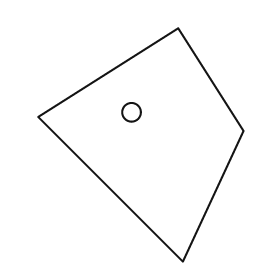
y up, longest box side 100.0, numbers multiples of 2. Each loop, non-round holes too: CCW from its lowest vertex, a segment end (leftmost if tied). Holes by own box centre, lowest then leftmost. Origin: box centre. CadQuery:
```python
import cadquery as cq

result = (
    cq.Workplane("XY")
    .moveTo(18.0, -50.0)
    .lineTo(44.0, 6.0)
    .lineTo(16.0, 50.0)
    .lineTo(-44.0, 12.0)
    .close()
    .moveTo(-4.0, 14.0)
    .circle(4.0)
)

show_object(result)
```